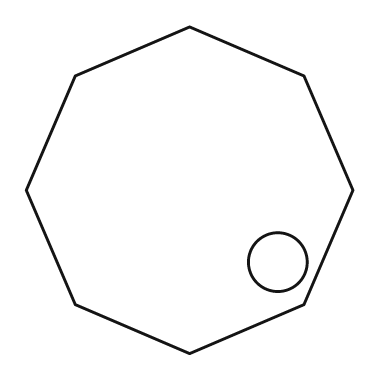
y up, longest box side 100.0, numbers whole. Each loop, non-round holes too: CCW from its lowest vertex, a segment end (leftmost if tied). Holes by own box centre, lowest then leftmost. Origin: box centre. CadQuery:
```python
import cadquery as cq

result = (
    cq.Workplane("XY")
    .moveTo(0.0, -50.0)
    .lineTo(35.0, -35.0)
    .lineTo(50.0, 0.0)
    .lineTo(35.0, 35.0)
    .lineTo(0.0, 50.0)
    .lineTo(-35.0, 35.0)
    .lineTo(-50.0, 0.0)
    .lineTo(-35.0, -35.0)
    .close()
    .moveTo(27.0, -22.0)
    .circle(9.0)
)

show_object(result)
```